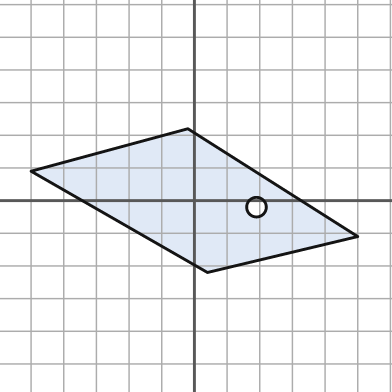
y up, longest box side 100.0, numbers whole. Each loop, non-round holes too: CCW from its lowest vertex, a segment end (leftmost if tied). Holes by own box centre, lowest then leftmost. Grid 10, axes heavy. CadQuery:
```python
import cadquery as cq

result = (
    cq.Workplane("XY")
    .moveTo(4.0, -22.0)
    .lineTo(50.0, -11.0)
    .lineTo(-2.0, 22.0)
    .lineTo(-50.0, 9.0)
    .close()
    .moveTo(19.0, -2.0)
    .circle(3.0)
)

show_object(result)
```